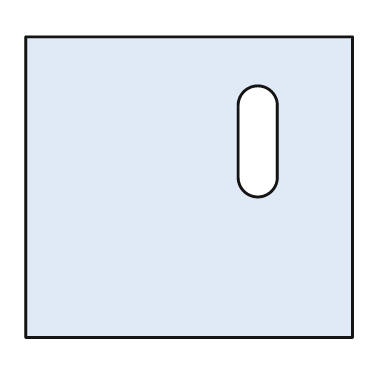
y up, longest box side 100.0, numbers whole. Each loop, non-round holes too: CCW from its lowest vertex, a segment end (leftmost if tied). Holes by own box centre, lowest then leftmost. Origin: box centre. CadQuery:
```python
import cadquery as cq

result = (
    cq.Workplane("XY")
    .moveTo(-50.0, -46.0)
    .lineTo(50.0, -46.0)
    .lineTo(50.0, 46.0)
    .lineTo(-50.0, 46.0)
    .close()
    .moveTo(15.0, 3.0)
    .threePointArc((21.0, -3.0), (27.0, 3.0))
    .lineTo(27.0, 25.0)
    .threePointArc((21.0, 31.0), (15.0, 25.0))
    .close()
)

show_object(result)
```